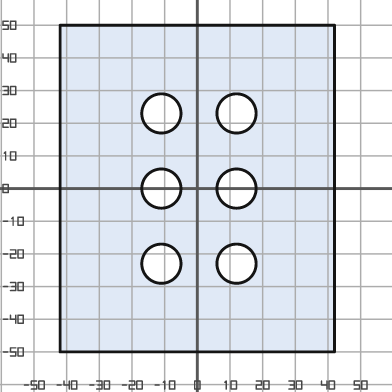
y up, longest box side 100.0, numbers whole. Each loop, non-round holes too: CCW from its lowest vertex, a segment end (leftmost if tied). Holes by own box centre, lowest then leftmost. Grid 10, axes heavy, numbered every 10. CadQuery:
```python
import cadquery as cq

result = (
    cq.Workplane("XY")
    .moveTo(-42.0, -50.0)
    .lineTo(42.0, -50.0)
    .lineTo(42.0, 50.0)
    .lineTo(-42.0, 50.0)
    .close()
    .moveTo(-11.0, -23.0)
    .circle(6.0)
    .moveTo(12.0, -23.0)
    .circle(6.0)
    .moveTo(-11.0, 0.0)
    .circle(6.0)
    .moveTo(12.0, 0.0)
    .circle(6.0)
    .moveTo(-11.0, 23.0)
    .circle(6.0)
    .moveTo(12.0, 23.0)
    .circle(6.0)
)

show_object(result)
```